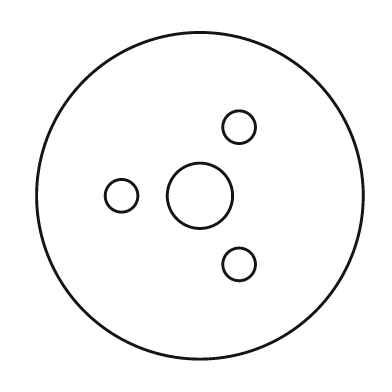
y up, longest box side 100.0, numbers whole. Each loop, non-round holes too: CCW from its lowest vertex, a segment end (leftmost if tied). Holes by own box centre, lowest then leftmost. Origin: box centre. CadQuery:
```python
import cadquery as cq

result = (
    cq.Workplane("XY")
    .moveTo(0.0, 0.0)
    .circle(50.0)
    .moveTo(12.0, -21.0)
    .circle(5.0)
    .moveTo(-24.0, 0.0)
    .circle(5.0)
    .moveTo(0.0, 0.0)
    .circle(10.0)
    .moveTo(12.0, 21.0)
    .circle(5.0)
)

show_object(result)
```